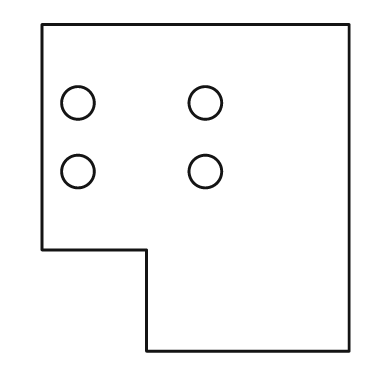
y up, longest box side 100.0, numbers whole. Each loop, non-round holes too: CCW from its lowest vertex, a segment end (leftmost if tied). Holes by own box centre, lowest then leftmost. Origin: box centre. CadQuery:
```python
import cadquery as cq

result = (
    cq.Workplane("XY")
    .moveTo(-15.0, -50.0)
    .lineTo(47.0, -50.0)
    .lineTo(47.0, 50.0)
    .lineTo(-47.0, 50.0)
    .lineTo(-47.0, -19.0)
    .lineTo(-15.0, -19.0)
    .close()
    .moveTo(-36.0, 5.0)
    .circle(5.0)
    .moveTo(3.0, 5.0)
    .circle(5.0)
    .moveTo(-36.0, 26.0)
    .circle(5.0)
    .moveTo(3.0, 26.0)
    .circle(5.0)
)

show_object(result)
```